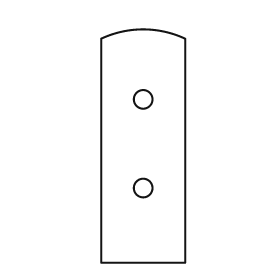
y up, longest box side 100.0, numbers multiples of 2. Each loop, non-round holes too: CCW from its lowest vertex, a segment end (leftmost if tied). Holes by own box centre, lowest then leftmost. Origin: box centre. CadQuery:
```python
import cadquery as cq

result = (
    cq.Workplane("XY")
    .moveTo(-18.0, -50.0)
    .lineTo(18.0, -50.0)
    .lineTo(18.0, 46.0)
    .threePointArc((0.0, 50.0), (-18.0, 46.0))
    .close()
    .moveTo(0.0, -18.0)
    .circle(4.0)
    .moveTo(0.0, 20.0)
    .circle(4.0)
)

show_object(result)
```